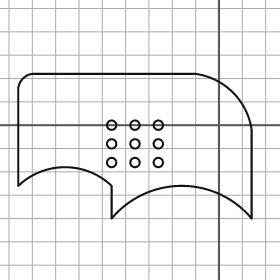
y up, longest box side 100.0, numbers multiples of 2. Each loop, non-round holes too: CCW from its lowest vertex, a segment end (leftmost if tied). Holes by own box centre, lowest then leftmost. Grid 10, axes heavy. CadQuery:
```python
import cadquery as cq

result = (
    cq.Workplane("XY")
    .moveTo(-46.0, -40.0)
    .threePointArc((-16.0, -26.0), (14.0, -40.0))
    .lineTo(14.0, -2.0)
    .threePointArc((6.0, 14.0), (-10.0, 22.0))
    .lineTo(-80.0, 22.0)
    .threePointArc((-84.0, 20.0), (-86.0, 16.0))
    .lineTo(-86.0, -26.0)
    .threePointArc((-66.0, -18.0), (-46.0, -26.0))
    .close()
    .moveTo(-46.0, -16.0)
    .circle(2.0)
    .moveTo(-36.0, -16.0)
    .circle(2.0)
    .moveTo(-26.0, -16.0)
    .circle(2.0)
    .moveTo(-46.0, -8.0)
    .circle(2.0)
    .moveTo(-36.0, -8.0)
    .circle(2.0)
    .moveTo(-26.0, -8.0)
    .circle(2.0)
    .moveTo(-46.0, 0.0)
    .circle(2.0)
    .moveTo(-36.0, 0.0)
    .circle(2.0)
    .moveTo(-26.0, 0.0)
    .circle(2.0)
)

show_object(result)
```